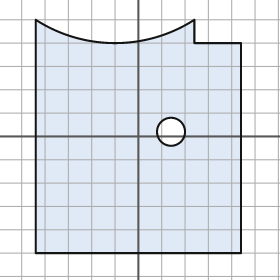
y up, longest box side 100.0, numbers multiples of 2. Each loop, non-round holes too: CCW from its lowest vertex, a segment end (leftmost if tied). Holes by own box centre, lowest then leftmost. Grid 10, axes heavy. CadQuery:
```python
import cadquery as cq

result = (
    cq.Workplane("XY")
    .moveTo(-44.0, -50.0)
    .lineTo(44.0, -50.0)
    .lineTo(44.0, 40.0)
    .lineTo(24.0, 40.0)
    .lineTo(24.0, 50.0)
    .threePointArc((-10.0, 40.0), (-44.0, 50.0))
    .close()
    .moveTo(14.0, 2.0)
    .circle(6.0)
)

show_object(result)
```